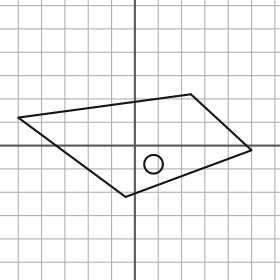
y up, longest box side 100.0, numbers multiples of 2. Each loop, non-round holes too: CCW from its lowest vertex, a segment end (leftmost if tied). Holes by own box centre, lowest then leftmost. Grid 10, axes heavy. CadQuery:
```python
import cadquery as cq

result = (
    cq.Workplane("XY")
    .moveTo(-4.0, -22.0)
    .lineTo(50.0, -2.0)
    .lineTo(24.0, 22.0)
    .lineTo(-50.0, 12.0)
    .close()
    .moveTo(8.0, -8.0)
    .circle(4.0)
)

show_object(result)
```